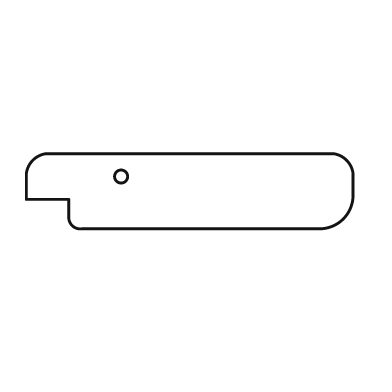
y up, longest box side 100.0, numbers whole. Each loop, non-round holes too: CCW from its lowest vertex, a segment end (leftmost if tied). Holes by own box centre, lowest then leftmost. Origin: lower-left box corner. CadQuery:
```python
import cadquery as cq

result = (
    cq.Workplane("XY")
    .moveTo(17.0, 0.0)
    .lineTo(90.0, 0.0)
    .threePointArc((97.0, 3.0), (100.0, 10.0))
    .lineTo(100.0, 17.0)
    .threePointArc((98.0, 21.0), (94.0, 23.0))
    .lineTo(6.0, 23.0)
    .threePointArc((2.0, 21.0), (0.0, 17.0))
    .lineTo(0.0, 9.0)
    .lineTo(13.0, 9.0)
    .lineTo(13.0, 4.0)
    .threePointArc((14.0, 1.0), (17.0, 0.0))
    .close()
    .moveTo(29.0, 16.0)
    .circle(2.0)
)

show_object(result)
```